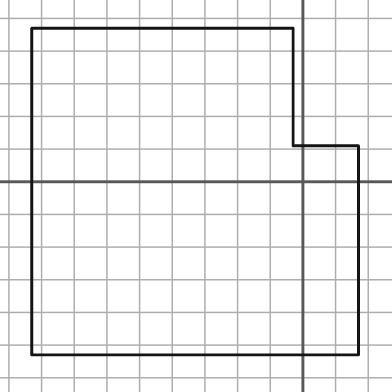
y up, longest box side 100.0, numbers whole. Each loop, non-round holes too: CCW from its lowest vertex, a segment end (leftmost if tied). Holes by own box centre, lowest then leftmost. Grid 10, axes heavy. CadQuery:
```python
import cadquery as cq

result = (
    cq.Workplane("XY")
    .moveTo(-83.0, -53.0)
    .lineTo(17.0, -53.0)
    .lineTo(17.0, 11.0)
    .lineTo(-3.0, 11.0)
    .lineTo(-3.0, 47.0)
    .lineTo(-83.0, 47.0)
    .close()
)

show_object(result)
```